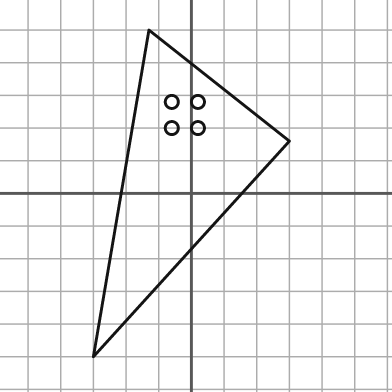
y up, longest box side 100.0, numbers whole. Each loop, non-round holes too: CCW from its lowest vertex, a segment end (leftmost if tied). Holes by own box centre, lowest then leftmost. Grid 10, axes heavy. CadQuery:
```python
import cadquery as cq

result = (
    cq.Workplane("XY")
    .moveTo(-30.0, -50.0)
    .lineTo(30.0, 16.0)
    .lineTo(-13.0, 50.0)
    .close()
    .moveTo(-6.0, 20.0)
    .circle(2.0)
    .moveTo(2.0, 20.0)
    .circle(2.0)
    .moveTo(-6.0, 28.0)
    .circle(2.0)
    .moveTo(2.0, 28.0)
    .circle(2.0)
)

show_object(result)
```